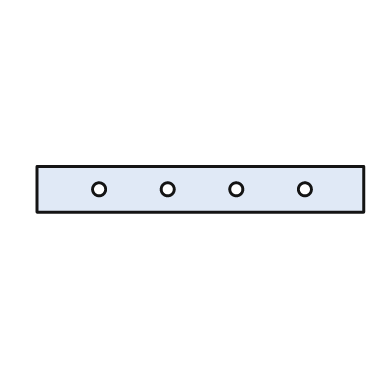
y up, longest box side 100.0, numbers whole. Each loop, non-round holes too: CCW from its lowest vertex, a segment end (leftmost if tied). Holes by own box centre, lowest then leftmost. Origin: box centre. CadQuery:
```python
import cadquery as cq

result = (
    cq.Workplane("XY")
    .moveTo(-50.0, -7.0)
    .lineTo(50.0, -7.0)
    .lineTo(50.0, 7.0)
    .lineTo(-50.0, 7.0)
    .close()
    .moveTo(-31.0, 0.0)
    .circle(2.0)
    .moveTo(-10.0, 0.0)
    .circle(2.0)
    .moveTo(11.0, 0.0)
    .circle(2.0)
    .moveTo(32.0, 0.0)
    .circle(2.0)
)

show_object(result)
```